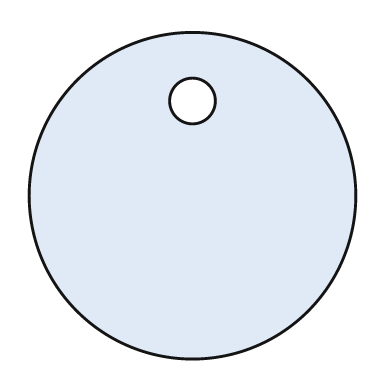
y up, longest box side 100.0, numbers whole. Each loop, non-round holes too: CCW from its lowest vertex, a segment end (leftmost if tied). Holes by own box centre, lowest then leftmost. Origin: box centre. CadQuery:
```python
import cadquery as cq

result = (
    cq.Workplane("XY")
    .moveTo(0.0, 0.0)
    .circle(50.0)
    .moveTo(0.0, 29.0)
    .circle(7.0)
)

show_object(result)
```